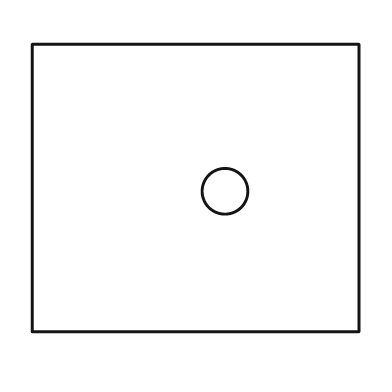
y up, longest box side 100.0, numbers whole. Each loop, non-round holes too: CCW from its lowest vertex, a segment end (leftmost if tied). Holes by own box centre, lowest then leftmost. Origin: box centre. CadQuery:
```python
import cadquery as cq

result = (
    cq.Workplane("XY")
    .moveTo(-50.0, -44.0)
    .lineTo(50.0, -44.0)
    .lineTo(50.0, 44.0)
    .lineTo(-50.0, 44.0)
    .close()
    .moveTo(9.0, -1.0)
    .circle(7.0)
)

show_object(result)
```